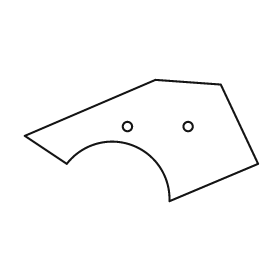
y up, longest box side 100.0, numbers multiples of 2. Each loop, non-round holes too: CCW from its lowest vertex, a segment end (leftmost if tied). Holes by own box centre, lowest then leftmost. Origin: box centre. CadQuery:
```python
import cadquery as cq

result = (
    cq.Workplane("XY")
    .moveTo(12.0, -26.0)
    .lineTo(50.0, -10.0)
    .lineTo(34.0, 24.0)
    .lineTo(6.0, 26.0)
    .lineTo(-50.0, 2.0)
    .lineTo(-32.0, -10.0)
    .threePointArc((-4.0, -2.0), (12.0, -26.0))
    .close()
    .moveTo(-6.0, 6.0)
    .circle(2.0)
    .moveTo(20.0, 6.0)
    .circle(2.0)
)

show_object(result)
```